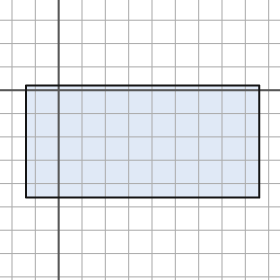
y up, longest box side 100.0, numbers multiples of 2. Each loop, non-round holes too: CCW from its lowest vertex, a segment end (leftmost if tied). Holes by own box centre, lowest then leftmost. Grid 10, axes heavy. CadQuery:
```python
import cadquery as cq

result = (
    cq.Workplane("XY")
    .moveTo(-14.0, -46.0)
    .lineTo(86.0, -46.0)
    .lineTo(86.0, 2.0)
    .lineTo(-14.0, 2.0)
    .close()
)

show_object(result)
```